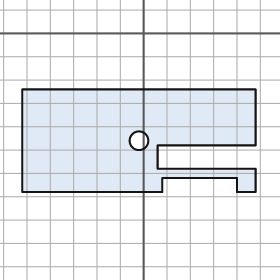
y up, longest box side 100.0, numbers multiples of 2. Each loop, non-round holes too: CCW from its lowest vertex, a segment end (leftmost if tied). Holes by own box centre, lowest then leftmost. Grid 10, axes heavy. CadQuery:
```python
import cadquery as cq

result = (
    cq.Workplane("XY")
    .moveTo(-52.0, -68.0)
    .lineTo(8.0, -68.0)
    .lineTo(8.0, -62.0)
    .lineTo(40.0, -62.0)
    .lineTo(40.0, -68.0)
    .lineTo(48.0, -68.0)
    .lineTo(48.0, -58.0)
    .lineTo(6.0, -58.0)
    .lineTo(6.0, -48.0)
    .lineTo(48.0, -48.0)
    .lineTo(48.0, -24.0)
    .lineTo(-52.0, -24.0)
    .close()
    .moveTo(-2.0, -46.0)
    .circle(4.0)
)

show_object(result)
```